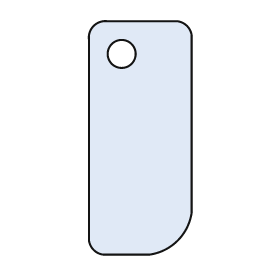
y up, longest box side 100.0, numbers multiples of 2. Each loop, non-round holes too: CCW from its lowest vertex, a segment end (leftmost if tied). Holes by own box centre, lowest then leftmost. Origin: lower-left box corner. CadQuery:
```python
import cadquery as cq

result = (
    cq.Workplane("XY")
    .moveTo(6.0, 0.0)
    .lineTo(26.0, 0.0)
    .threePointArc((38.0, 6.0), (44.0, 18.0))
    .lineTo(44.0, 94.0)
    .threePointArc((42.0, 98.0), (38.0, 100.0))
    .lineTo(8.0, 100.0)
    .threePointArc((2.0, 98.0), (0.0, 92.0))
    .lineTo(0.0, 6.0)
    .threePointArc((2.0, 2.0), (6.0, 0.0))
    .close()
    .moveTo(14.0, 86.0)
    .circle(6.0)
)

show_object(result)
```